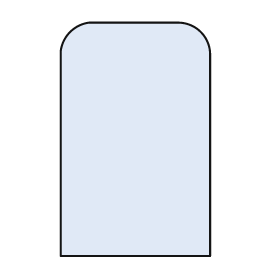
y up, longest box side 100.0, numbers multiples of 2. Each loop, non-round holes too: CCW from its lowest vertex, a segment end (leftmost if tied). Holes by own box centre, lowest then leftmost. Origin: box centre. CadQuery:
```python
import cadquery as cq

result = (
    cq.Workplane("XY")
    .moveTo(-32.0, -50.0)
    .lineTo(32.0, -50.0)
    .lineTo(32.0, 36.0)
    .threePointArc((28.0, 46.0), (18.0, 50.0))
    .lineTo(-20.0, 50.0)
    .threePointArc((-28.0, 46.0), (-32.0, 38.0))
    .close()
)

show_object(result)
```